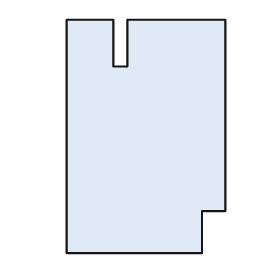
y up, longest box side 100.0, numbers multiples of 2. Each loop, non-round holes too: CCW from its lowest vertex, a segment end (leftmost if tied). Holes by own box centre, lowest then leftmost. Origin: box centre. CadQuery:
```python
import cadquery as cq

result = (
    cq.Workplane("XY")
    .moveTo(-34.0, -50.0)
    .lineTo(24.0, -50.0)
    .lineTo(24.0, -32.0)
    .lineTo(34.0, -32.0)
    .lineTo(34.0, 50.0)
    .lineTo(-8.0, 50.0)
    .lineTo(-8.0, 30.0)
    .lineTo(-14.0, 30.0)
    .lineTo(-14.0, 50.0)
    .lineTo(-34.0, 50.0)
    .close()
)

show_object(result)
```